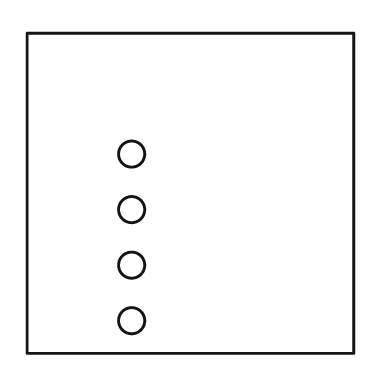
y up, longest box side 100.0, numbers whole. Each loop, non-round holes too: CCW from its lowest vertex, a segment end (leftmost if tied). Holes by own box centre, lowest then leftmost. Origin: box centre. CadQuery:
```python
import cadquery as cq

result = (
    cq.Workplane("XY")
    .moveTo(-50.0, -49.0)
    .lineTo(50.0, -49.0)
    .lineTo(50.0, 49.0)
    .lineTo(-50.0, 49.0)
    .close()
    .moveTo(-18.0, -39.0)
    .circle(4.0)
    .moveTo(-18.0, -22.0)
    .circle(4.0)
    .moveTo(-18.0, -5.0)
    .circle(4.0)
    .moveTo(-18.0, 12.0)
    .circle(4.0)
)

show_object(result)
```